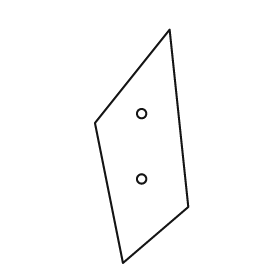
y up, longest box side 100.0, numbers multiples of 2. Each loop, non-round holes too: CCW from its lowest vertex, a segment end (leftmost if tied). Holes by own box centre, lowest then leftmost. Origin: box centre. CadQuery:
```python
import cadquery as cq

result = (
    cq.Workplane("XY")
    .moveTo(-8.0, -50.0)
    .lineTo(20.0, -26.0)
    .lineTo(12.0, 50.0)
    .lineTo(-20.0, 10.0)
    .close()
    .moveTo(0.0, -14.0)
    .circle(2.0)
    .moveTo(0.0, 14.0)
    .circle(2.0)
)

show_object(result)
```